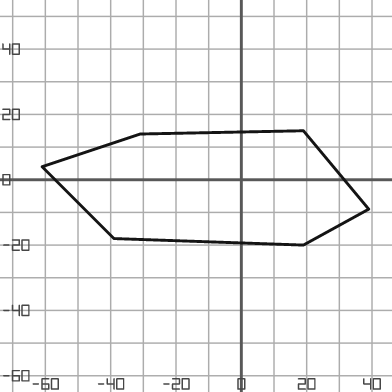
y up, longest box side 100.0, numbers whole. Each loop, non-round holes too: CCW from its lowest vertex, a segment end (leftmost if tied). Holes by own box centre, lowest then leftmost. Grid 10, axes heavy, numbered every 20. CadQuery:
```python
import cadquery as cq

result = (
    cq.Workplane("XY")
    .moveTo(19.0, -20.0)
    .lineTo(39.0, -9.0)
    .lineTo(19.0, 15.0)
    .lineTo(-31.0, 14.0)
    .lineTo(-61.0, 4.0)
    .lineTo(-39.0, -18.0)
    .close()
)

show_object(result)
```